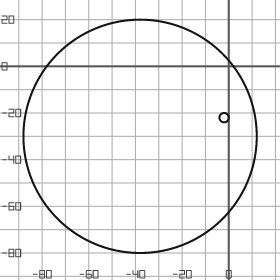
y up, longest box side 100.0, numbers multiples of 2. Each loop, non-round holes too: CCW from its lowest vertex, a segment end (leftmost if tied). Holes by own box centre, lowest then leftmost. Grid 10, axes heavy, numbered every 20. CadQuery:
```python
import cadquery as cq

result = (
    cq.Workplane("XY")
    .moveTo(-38.0, -30.0)
    .circle(50.0)
    .moveTo(-2.0, -22.0)
    .circle(2.0)
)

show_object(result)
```